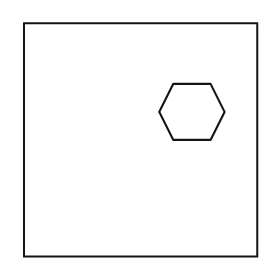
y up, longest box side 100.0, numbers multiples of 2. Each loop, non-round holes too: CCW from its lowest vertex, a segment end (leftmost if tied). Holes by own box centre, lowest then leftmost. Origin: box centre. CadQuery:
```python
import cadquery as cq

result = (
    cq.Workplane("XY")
    .moveTo(-50.0, -50.0)
    .lineTo(50.0, -50.0)
    .lineTo(50.0, 50.0)
    .lineTo(-50.0, 50.0)
    .close()
    .moveTo(14.0, 0.0)
    .lineTo(30.0, 0.0)
    .lineTo(36.0, 12.0)
    .lineTo(30.0, 24.0)
    .lineTo(14.0, 24.0)
    .lineTo(8.0, 12.0)
    .close()
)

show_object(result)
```